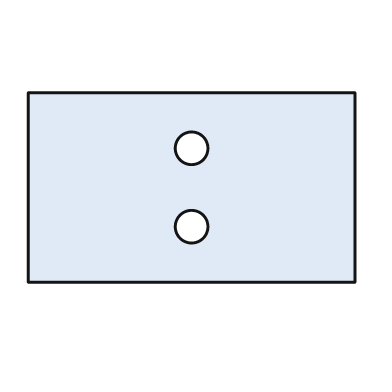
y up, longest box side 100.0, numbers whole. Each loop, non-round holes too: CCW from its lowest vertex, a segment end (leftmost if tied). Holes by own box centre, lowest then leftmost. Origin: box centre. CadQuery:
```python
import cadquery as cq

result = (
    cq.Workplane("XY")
    .moveTo(-50.0, -29.0)
    .lineTo(50.0, -29.0)
    .lineTo(50.0, 29.0)
    .lineTo(-50.0, 29.0)
    .close()
    .moveTo(0.0, -12.0)
    .circle(5.0)
    .moveTo(0.0, 12.0)
    .circle(5.0)
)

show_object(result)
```